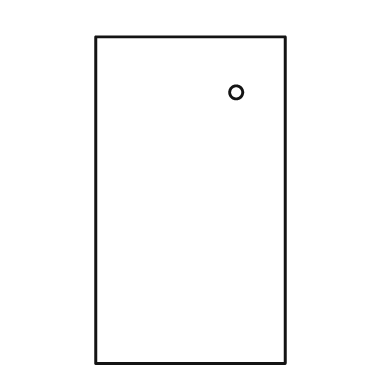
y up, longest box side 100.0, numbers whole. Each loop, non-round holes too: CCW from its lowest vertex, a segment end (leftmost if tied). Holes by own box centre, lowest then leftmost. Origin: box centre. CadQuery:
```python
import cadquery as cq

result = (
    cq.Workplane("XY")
    .moveTo(-29.0, -50.0)
    .lineTo(29.0, -50.0)
    .lineTo(29.0, 50.0)
    .lineTo(-29.0, 50.0)
    .close()
    .moveTo(14.0, 33.0)
    .circle(2.0)
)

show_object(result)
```